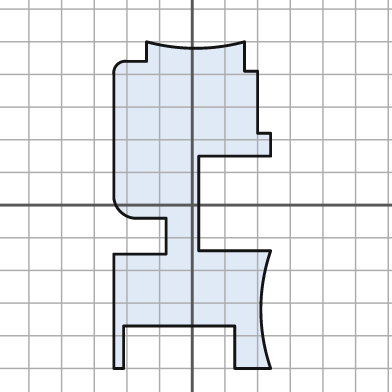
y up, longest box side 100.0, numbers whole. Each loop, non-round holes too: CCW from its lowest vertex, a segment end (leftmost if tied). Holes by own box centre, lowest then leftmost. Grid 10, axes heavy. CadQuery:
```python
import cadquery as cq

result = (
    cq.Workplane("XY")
    .moveTo(-24.0, -50.0)
    .lineTo(-21.0, -50.0)
    .lineTo(-21.0, -37.0)
    .lineTo(13.0, -37.0)
    .lineTo(13.0, -50.0)
    .lineTo(24.0, -50.0)
    .threePointArc((21.0, -32.0), (24.0, -14.0))
    .lineTo(2.0, -14.0)
    .lineTo(2.0, 15.0)
    .lineTo(24.0, 15.0)
    .lineTo(24.0, 22.0)
    .lineTo(20.0, 22.0)
    .lineTo(20.0, 41.0)
    .lineTo(16.0, 41.0)
    .lineTo(16.0, 50.0)
    .threePointArc((1.0, 48.0), (-14.0, 50.0))
    .lineTo(-14.0, 44.0)
    .lineTo(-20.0, 44.0)
    .threePointArc((-23.0, 43.0), (-24.0, 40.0))
    .lineTo(-24.0, 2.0)
    .threePointArc((-22.0, -2.0), (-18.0, -4.0))
    .lineTo(-8.0, -4.0)
    .lineTo(-8.0, -15.0)
    .lineTo(-24.0, -15.0)
    .close()
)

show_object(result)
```